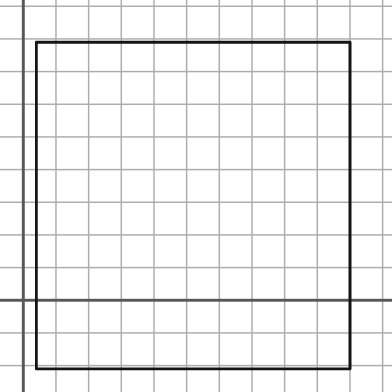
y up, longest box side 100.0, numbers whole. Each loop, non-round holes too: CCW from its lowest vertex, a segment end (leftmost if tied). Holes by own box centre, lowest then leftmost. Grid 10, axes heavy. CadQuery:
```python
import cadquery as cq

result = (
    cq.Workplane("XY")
    .moveTo(4.0, -21.0)
    .lineTo(100.0, -21.0)
    .lineTo(100.0, 79.0)
    .lineTo(4.0, 79.0)
    .close()
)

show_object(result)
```